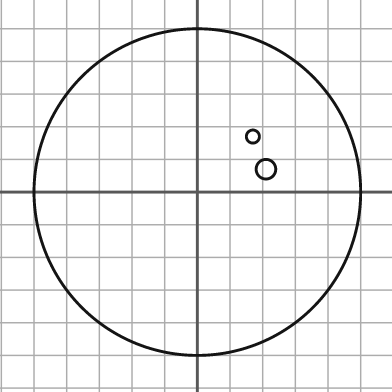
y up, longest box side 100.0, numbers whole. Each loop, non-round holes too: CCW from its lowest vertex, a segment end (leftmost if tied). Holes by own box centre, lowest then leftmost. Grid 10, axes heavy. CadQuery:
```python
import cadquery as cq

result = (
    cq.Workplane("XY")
    .moveTo(0.0, 0.0)
    .circle(50.0)
    .moveTo(21.0, 7.0)
    .circle(3.0)
    .moveTo(17.0, 17.0)
    .circle(2.0)
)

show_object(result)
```